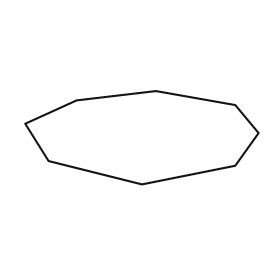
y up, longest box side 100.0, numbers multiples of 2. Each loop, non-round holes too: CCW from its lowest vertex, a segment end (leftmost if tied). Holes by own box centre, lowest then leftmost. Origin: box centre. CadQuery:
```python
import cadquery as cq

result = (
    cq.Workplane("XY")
    .moveTo(0.0, -20.0)
    .lineTo(40.0, -12.0)
    .lineTo(50.0, 2.0)
    .lineTo(40.0, 14.0)
    .lineTo(6.0, 20.0)
    .lineTo(-28.0, 16.0)
    .lineTo(-50.0, 6.0)
    .lineTo(-40.0, -10.0)
    .close()
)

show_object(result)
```